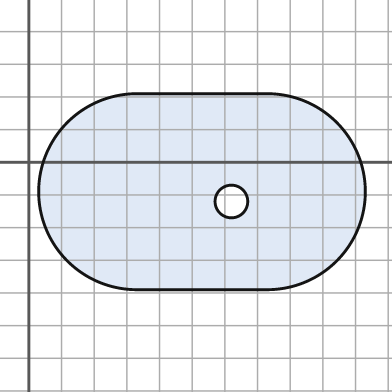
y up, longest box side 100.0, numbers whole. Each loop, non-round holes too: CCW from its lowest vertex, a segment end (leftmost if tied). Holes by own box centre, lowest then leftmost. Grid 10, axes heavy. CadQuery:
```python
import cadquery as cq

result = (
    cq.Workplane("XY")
    .moveTo(33.0, -39.0)
    .lineTo(73.0, -39.0)
    .threePointArc((103.0, -9.0), (73.0, 21.0))
    .lineTo(33.0, 21.0)
    .threePointArc((3.0, -9.0), (33.0, -39.0))
    .close()
    .moveTo(62.0, -12.0)
    .circle(5.0)
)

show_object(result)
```